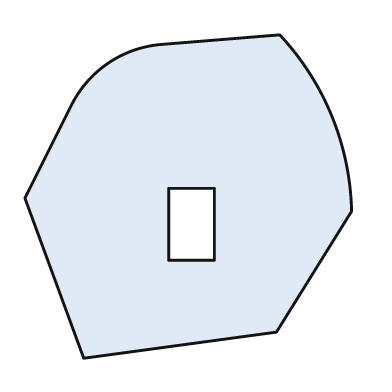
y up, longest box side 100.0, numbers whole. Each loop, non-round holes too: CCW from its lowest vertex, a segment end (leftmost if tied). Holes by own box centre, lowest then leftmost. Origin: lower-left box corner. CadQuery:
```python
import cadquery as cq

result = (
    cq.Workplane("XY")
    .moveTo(18.0, 0.0)
    .lineTo(77.0, 8.0)
    .lineTo(100.0, 45.0)
    .threePointArc((94.0, 74.0), (78.0, 99.0))
    .lineTo(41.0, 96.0)
    .threePointArc((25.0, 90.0), (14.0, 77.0))
    .lineTo(0.0, 49.0)
    .close()
    .moveTo(44.0, 30.0)
    .lineTo(58.0, 30.0)
    .lineTo(58.0, 52.0)
    .lineTo(44.0, 52.0)
    .close()
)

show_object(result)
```